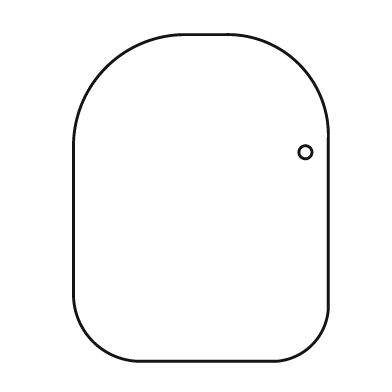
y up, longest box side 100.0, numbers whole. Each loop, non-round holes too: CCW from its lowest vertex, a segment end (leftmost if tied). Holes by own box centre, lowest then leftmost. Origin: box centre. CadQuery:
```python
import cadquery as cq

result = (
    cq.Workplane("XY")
    .moveTo(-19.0, -50.0)
    .lineTo(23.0, -50.0)
    .threePointArc((34.0, -45.0), (39.0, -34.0))
    .lineTo(39.0, 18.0)
    .threePointArc((30.0, 41.0), (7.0, 50.0))
    .lineTo(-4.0, 50.0)
    .threePointArc((-29.0, 40.0), (-39.0, 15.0))
    .lineTo(-39.0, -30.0)
    .threePointArc((-33.0, -44.0), (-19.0, -50.0))
    .close()
    .moveTo(32.0, 14.0)
    .circle(2.0)
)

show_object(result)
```